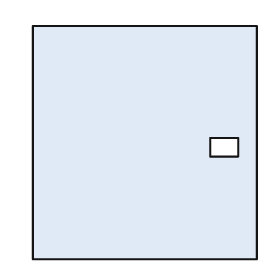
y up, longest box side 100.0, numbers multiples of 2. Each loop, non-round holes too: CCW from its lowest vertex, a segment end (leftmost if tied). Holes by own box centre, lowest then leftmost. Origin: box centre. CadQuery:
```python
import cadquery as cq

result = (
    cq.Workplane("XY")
    .moveTo(-48.0, -50.0)
    .lineTo(48.0, -50.0)
    .lineTo(48.0, 50.0)
    .lineTo(-48.0, 50.0)
    .close()
    .moveTo(28.0, -6.0)
    .lineTo(40.0, -6.0)
    .lineTo(40.0, 2.0)
    .lineTo(28.0, 2.0)
    .close()
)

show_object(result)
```